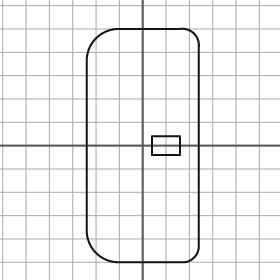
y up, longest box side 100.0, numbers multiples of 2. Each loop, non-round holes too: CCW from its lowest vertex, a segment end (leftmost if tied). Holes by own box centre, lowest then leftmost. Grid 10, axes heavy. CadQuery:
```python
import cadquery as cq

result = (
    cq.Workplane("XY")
    .moveTo(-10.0, -50.0)
    .lineTo(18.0, -50.0)
    .threePointArc((22.0, -48.0), (24.0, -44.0))
    .lineTo(24.0, 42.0)
    .threePointArc((22.0, 48.0), (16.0, 50.0))
    .lineTo(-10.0, 50.0)
    .threePointArc((-20.0, 46.0), (-24.0, 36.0))
    .lineTo(-24.0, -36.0)
    .threePointArc((-20.0, -46.0), (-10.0, -50.0))
    .close()
    .moveTo(4.0, -4.0)
    .lineTo(16.0, -4.0)
    .lineTo(16.0, 4.0)
    .lineTo(4.0, 4.0)
    .close()
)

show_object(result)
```